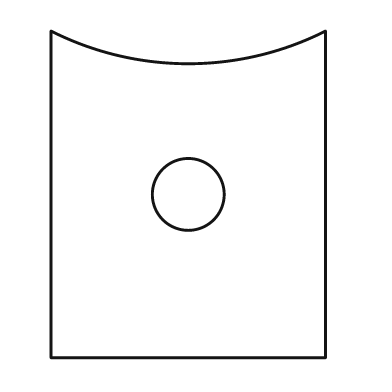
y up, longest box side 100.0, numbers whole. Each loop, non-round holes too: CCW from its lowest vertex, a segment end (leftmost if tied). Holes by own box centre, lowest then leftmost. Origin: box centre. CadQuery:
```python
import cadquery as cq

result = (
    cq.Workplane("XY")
    .moveTo(-42.0, -50.0)
    .lineTo(42.0, -50.0)
    .lineTo(42.0, 50.0)
    .threePointArc((0.0, 40.0), (-42.0, 50.0))
    .close()
    .moveTo(0.0, 0.0)
    .circle(11.0)
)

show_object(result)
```